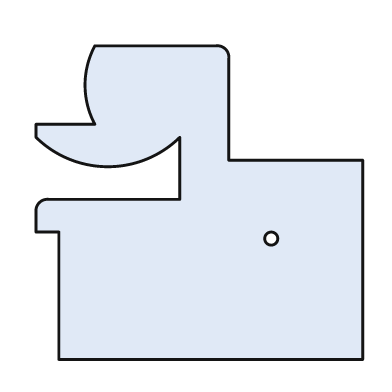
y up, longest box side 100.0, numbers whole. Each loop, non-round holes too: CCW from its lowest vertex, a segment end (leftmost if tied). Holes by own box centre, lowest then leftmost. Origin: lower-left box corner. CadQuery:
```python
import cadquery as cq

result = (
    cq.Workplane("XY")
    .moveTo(7.0, 0.0)
    .lineTo(100.0, 0.0)
    .lineTo(100.0, 61.0)
    .lineTo(59.0, 61.0)
    .lineTo(59.0, 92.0)
    .threePointArc((58.0, 95.0), (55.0, 96.0))
    .lineTo(18.0, 96.0)
    .threePointArc((15.0, 84.0), (18.0, 72.0))
    .lineTo(0.0, 72.0)
    .lineTo(0.0, 68.0)
    .threePointArc((22.0, 59.0), (44.0, 68.0))
    .lineTo(44.0, 49.0)
    .lineTo(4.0, 49.0)
    .threePointArc((1.0, 48.0), (0.0, 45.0))
    .lineTo(0.0, 39.0)
    .lineTo(7.0, 39.0)
    .close()
    .moveTo(72.0, 37.0)
    .circle(2.0)
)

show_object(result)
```